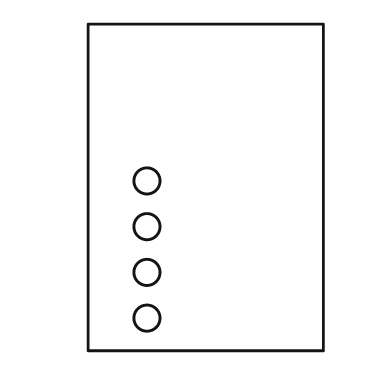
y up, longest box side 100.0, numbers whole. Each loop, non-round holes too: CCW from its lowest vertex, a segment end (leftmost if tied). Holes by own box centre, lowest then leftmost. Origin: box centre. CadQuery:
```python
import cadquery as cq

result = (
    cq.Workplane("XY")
    .moveTo(-36.0, -50.0)
    .lineTo(36.0, -50.0)
    .lineTo(36.0, 50.0)
    .lineTo(-36.0, 50.0)
    .close()
    .moveTo(-18.0, -40.0)
    .circle(4.0)
    .moveTo(-18.0, -26.0)
    .circle(4.0)
    .moveTo(-18.0, -12.0)
    .circle(4.0)
    .moveTo(-18.0, 2.0)
    .circle(4.0)
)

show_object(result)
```